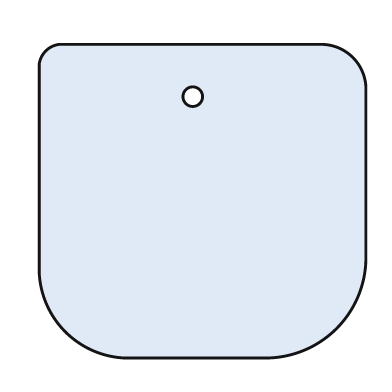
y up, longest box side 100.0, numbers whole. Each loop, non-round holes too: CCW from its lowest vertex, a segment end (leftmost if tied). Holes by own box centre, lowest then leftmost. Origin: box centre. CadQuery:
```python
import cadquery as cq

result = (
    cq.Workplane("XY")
    .moveTo(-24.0, -48.0)
    .lineTo(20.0, -48.0)
    .threePointArc((41.0, -39.0), (50.0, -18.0))
    .lineTo(50.0, 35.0)
    .threePointArc((46.0, 44.0), (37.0, 48.0))
    .lineTo(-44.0, 48.0)
    .threePointArc((-48.0, 46.0), (-50.0, 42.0))
    .lineTo(-50.0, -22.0)
    .threePointArc((-42.0, -40.0), (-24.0, -48.0))
    .close()
    .moveTo(-3.0, 32.0)
    .circle(3.0)
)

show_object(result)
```